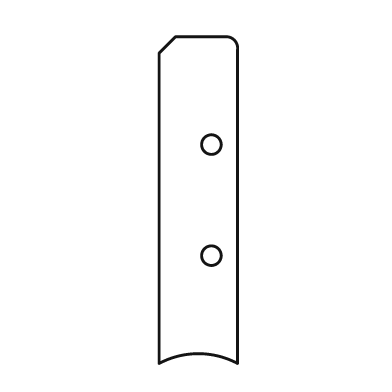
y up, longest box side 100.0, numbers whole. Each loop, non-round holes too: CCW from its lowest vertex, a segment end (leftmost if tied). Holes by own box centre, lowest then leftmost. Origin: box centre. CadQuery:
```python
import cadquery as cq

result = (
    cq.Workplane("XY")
    .moveTo(-12.0, -50.0)
    .threePointArc((0.0, -47.0), (12.0, -50.0))
    .lineTo(12.0, 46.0)
    .threePointArc((11.0, 49.0), (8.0, 50.0))
    .lineTo(-7.0, 50.0)
    .lineTo(-12.0, 45.0)
    .close()
    .moveTo(4.0, -17.0)
    .circle(3.0)
    .moveTo(4.0, 17.0)
    .circle(3.0)
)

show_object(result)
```